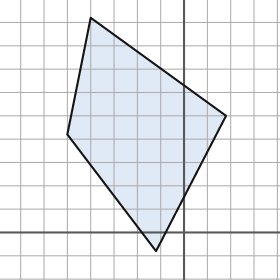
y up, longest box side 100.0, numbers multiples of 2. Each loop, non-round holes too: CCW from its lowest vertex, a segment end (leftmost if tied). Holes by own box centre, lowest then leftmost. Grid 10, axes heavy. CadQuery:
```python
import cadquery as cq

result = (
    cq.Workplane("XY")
    .moveTo(-12.0, -8.0)
    .lineTo(18.0, 50.0)
    .lineTo(-40.0, 92.0)
    .lineTo(-50.0, 42.0)
    .close()
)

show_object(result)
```